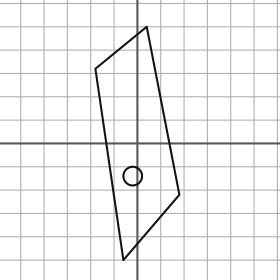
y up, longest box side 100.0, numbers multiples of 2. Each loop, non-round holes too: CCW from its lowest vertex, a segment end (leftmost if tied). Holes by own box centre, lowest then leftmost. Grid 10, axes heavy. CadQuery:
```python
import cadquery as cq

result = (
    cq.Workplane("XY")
    .moveTo(-6.0, -50.0)
    .lineTo(18.0, -22.0)
    .lineTo(4.0, 50.0)
    .lineTo(-18.0, 32.0)
    .close()
    .moveTo(-2.0, -14.0)
    .circle(4.0)
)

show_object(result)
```